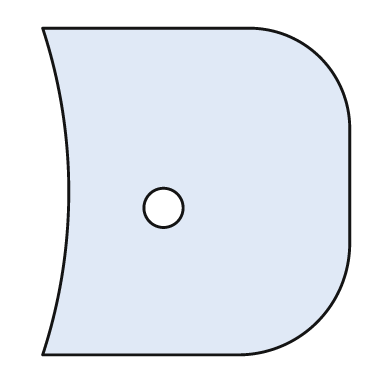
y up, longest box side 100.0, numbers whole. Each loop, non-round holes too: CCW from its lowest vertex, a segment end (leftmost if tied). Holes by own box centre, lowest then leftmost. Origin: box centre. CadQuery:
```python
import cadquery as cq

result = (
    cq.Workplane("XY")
    .moveTo(-47.0, -50.0)
    .lineTo(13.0, -50.0)
    .threePointArc((37.0, -40.0), (47.0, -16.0))
    .lineTo(47.0, 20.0)
    .threePointArc((38.0, 41.0), (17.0, 50.0))
    .lineTo(-47.0, 50.0)
    .threePointArc((-39.0, 0.0), (-47.0, -50.0))
    .close()
    .moveTo(-10.0, -5.0)
    .circle(6.0)
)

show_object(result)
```